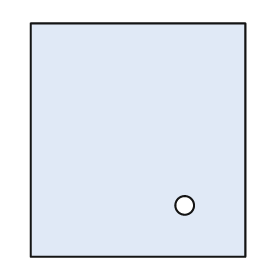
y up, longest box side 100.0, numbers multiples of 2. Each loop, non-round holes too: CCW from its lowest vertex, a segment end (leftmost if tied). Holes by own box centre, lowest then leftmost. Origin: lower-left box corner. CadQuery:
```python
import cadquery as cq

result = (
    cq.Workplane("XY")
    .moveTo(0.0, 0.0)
    .lineTo(92.0, 0.0)
    .lineTo(92.0, 100.0)
    .lineTo(0.0, 100.0)
    .close()
    .moveTo(66.0, 22.0)
    .circle(4.0)
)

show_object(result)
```